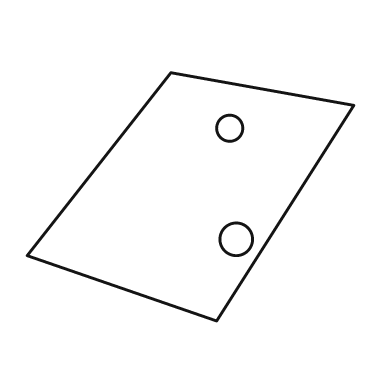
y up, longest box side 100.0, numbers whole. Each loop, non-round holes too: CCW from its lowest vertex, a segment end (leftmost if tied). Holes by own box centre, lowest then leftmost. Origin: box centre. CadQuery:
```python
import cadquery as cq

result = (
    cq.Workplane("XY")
    .moveTo(8.0, -38.0)
    .lineTo(50.0, 28.0)
    .lineTo(-6.0, 38.0)
    .lineTo(-50.0, -18.0)
    .close()
    .moveTo(14.0, -13.0)
    .circle(5.0)
    .moveTo(12.0, 21.0)
    .circle(4.0)
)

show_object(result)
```